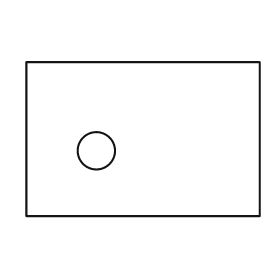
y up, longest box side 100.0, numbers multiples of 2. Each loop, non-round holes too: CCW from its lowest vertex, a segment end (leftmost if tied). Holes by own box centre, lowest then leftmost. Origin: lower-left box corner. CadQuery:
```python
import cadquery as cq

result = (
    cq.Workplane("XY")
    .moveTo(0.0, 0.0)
    .lineTo(100.0, 0.0)
    .lineTo(100.0, 66.0)
    .lineTo(0.0, 66.0)
    .close()
    .moveTo(30.0, 28.0)
    .circle(8.0)
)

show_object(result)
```